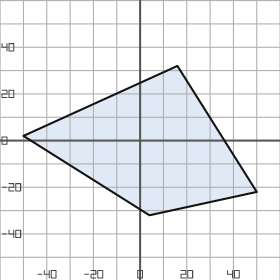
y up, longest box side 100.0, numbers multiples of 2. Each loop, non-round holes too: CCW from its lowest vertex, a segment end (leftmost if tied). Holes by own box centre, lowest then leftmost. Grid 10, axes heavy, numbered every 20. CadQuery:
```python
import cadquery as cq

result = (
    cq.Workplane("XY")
    .moveTo(4.0, -32.0)
    .lineTo(50.0, -22.0)
    .lineTo(16.0, 32.0)
    .lineTo(-50.0, 2.0)
    .close()
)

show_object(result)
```